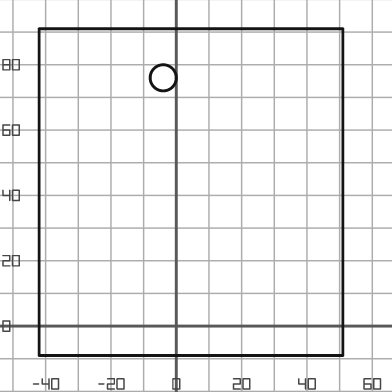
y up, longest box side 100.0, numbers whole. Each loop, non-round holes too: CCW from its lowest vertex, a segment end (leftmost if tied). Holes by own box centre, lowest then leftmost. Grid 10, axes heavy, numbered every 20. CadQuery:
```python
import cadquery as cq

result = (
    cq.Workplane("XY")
    .moveTo(-42.0, -9.0)
    .lineTo(51.0, -9.0)
    .lineTo(51.0, 91.0)
    .lineTo(-42.0, 91.0)
    .close()
    .moveTo(-4.0, 76.0)
    .circle(4.0)
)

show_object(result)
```